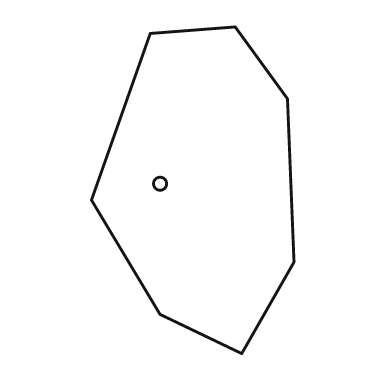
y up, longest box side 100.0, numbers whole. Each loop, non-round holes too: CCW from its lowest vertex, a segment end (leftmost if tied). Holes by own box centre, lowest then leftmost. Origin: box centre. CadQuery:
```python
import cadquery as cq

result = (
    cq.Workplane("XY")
    .moveTo(15.0, -50.0)
    .lineTo(31.0, -22.0)
    .lineTo(29.0, 28.0)
    .lineTo(13.0, 50.0)
    .lineTo(-13.0, 48.0)
    .lineTo(-31.0, -3.0)
    .lineTo(-10.0, -38.0)
    .close()
    .moveTo(-10.0, 2.0)
    .circle(2.0)
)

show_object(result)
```